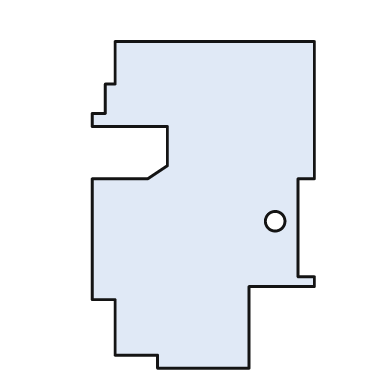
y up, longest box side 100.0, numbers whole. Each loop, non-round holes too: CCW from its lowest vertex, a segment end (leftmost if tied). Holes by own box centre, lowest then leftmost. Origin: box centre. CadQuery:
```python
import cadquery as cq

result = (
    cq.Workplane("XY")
    .moveTo(-14.0, -50.0)
    .lineTo(14.0, -50.0)
    .lineTo(14.0, -25.0)
    .lineTo(34.0, -25.0)
    .lineTo(34.0, -22.0)
    .lineTo(29.0, -22.0)
    .lineTo(29.0, 8.0)
    .lineTo(34.0, 8.0)
    .lineTo(34.0, 50.0)
    .lineTo(-27.0, 50.0)
    .lineTo(-27.0, 37.0)
    .lineTo(-30.0, 37.0)
    .lineTo(-30.0, 28.0)
    .lineTo(-34.0, 28.0)
    .lineTo(-34.0, 24.0)
    .lineTo(-11.0, 24.0)
    .lineTo(-11.0, 12.0)
    .lineTo(-17.0, 8.0)
    .lineTo(-34.0, 8.0)
    .lineTo(-34.0, -29.0)
    .lineTo(-27.0, -29.0)
    .lineTo(-27.0, -46.0)
    .lineTo(-14.0, -46.0)
    .close()
    .moveTo(22.0, -5.0)
    .circle(3.0)
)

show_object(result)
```